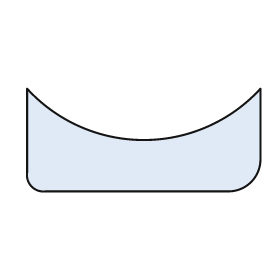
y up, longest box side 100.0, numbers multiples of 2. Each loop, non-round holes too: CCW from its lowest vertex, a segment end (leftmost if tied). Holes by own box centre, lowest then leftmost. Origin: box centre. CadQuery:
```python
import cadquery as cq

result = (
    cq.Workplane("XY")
    .moveTo(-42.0, -22.0)
    .lineTo(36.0, -22.0)
    .threePointArc((46.0, -18.0), (50.0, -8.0))
    .lineTo(50.0, 22.0)
    .threePointArc((0.0, 0.0), (-50.0, 22.0))
    .lineTo(-50.0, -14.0)
    .threePointArc((-48.0, -20.0), (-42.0, -22.0))
    .close()
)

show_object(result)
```